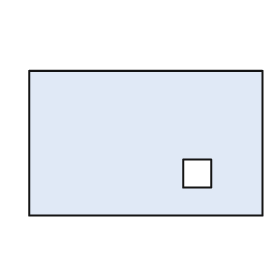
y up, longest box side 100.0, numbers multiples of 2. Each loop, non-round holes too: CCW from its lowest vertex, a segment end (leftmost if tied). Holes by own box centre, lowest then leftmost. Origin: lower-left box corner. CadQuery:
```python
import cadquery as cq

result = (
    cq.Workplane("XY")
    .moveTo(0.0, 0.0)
    .lineTo(100.0, 0.0)
    .lineTo(100.0, 62.0)
    .lineTo(0.0, 62.0)
    .close()
    .moveTo(66.0, 12.0)
    .lineTo(78.0, 12.0)
    .lineTo(78.0, 24.0)
    .lineTo(66.0, 24.0)
    .close()
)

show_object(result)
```